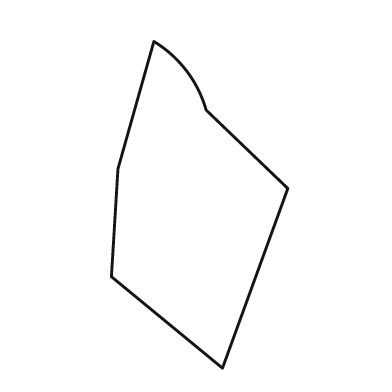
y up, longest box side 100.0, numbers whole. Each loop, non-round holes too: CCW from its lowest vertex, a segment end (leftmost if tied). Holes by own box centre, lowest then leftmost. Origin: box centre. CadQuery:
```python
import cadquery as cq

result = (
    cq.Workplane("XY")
    .moveTo(7.0, -50.0)
    .lineTo(27.0, 5.0)
    .lineTo(2.0, 29.0)
    .threePointArc((-4.0, 41.0), (-14.0, 50.0))
    .lineTo(-25.0, 11.0)
    .lineTo(-27.0, -22.0)
    .close()
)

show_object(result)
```